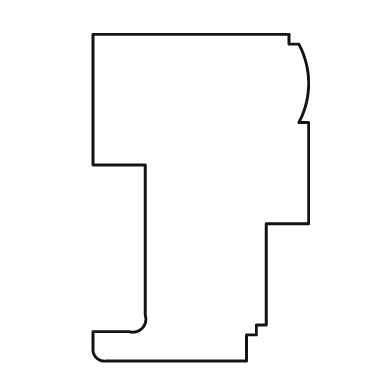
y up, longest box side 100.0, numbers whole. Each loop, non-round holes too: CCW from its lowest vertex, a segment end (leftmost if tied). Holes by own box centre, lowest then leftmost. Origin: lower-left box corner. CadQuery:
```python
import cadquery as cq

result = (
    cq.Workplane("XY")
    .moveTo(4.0, 0.0)
    .lineTo(47.0, 0.0)
    .lineTo(47.0, 8.0)
    .lineTo(50.0, 8.0)
    .lineTo(50.0, 11.0)
    .lineTo(53.0, 11.0)
    .lineTo(53.0, 42.0)
    .lineTo(66.0, 42.0)
    .lineTo(66.0, 73.0)
    .lineTo(63.0, 73.0)
    .threePointArc((66.0, 85.0), (63.0, 97.0))
    .lineTo(60.0, 97.0)
    .lineTo(60.0, 100.0)
    .lineTo(0.0, 100.0)
    .lineTo(0.0, 60.0)
    .lineTo(16.0, 60.0)
    .lineTo(16.0, 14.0)
    .threePointArc((15.0, 10.0), (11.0, 9.0))
    .lineTo(0.0, 9.0)
    .lineTo(0.0, 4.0)
    .threePointArc((1.0, 1.0), (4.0, 0.0))
    .close()
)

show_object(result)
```